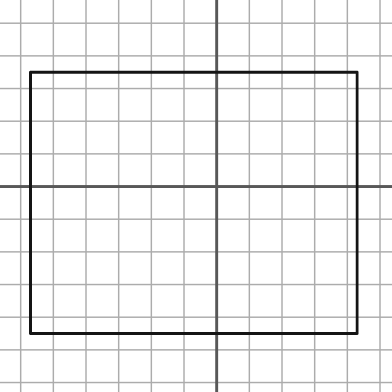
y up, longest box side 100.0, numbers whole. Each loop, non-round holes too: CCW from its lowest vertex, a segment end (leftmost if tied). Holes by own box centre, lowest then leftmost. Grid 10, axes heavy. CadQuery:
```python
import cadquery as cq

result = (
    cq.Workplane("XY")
    .moveTo(-57.0, -45.0)
    .lineTo(43.0, -45.0)
    .lineTo(43.0, 35.0)
    .lineTo(-57.0, 35.0)
    .close()
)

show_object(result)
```